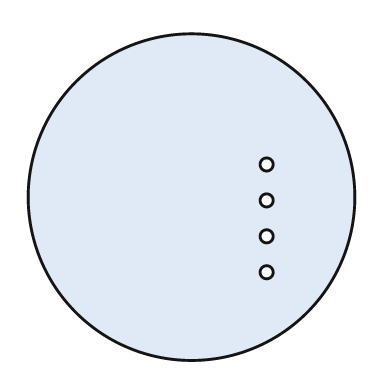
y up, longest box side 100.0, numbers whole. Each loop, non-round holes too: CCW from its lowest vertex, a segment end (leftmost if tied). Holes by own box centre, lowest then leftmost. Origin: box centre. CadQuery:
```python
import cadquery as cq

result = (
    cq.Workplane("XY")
    .moveTo(0.0, 0.0)
    .circle(50.0)
    .moveTo(23.0, -23.0)
    .circle(2.0)
    .moveTo(23.0, -12.0)
    .circle(2.0)
    .moveTo(23.0, -1.0)
    .circle(2.0)
    .moveTo(23.0, 10.0)
    .circle(2.0)
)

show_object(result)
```